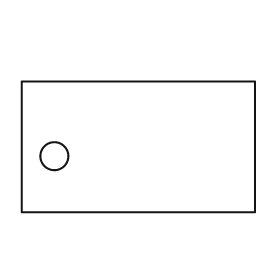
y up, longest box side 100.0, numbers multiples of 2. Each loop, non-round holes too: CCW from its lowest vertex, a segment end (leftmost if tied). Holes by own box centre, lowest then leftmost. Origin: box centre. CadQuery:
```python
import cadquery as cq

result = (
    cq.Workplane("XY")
    .moveTo(-50.0, -28.0)
    .lineTo(50.0, -28.0)
    .lineTo(50.0, 28.0)
    .lineTo(-50.0, 28.0)
    .close()
    .moveTo(-36.0, -4.0)
    .circle(6.0)
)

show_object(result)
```